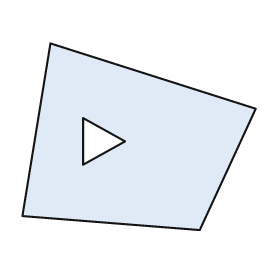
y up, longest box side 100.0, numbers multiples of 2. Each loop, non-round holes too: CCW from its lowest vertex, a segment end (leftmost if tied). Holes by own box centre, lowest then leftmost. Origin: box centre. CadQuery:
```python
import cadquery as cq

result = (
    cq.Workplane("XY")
    .moveTo(26.0, -40.0)
    .lineTo(50.0, 12.0)
    .lineTo(-38.0, 40.0)
    .lineTo(-50.0, -34.0)
    .close()
    .moveTo(-24.0, -12.0)
    .lineTo(-6.0, -2.0)
    .lineTo(-24.0, 8.0)
    .close()
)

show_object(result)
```